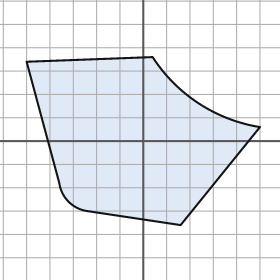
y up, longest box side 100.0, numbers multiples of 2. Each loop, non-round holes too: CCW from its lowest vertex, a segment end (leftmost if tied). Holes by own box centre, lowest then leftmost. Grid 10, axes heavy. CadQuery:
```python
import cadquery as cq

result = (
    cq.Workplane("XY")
    .moveTo(16.0, -36.0)
    .lineTo(50.0, 6.0)
    .threePointArc((24.0, 16.0), (4.0, 36.0))
    .lineTo(-50.0, 34.0)
    .lineTo(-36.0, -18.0)
    .threePointArc((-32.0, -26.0), (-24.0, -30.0))
    .close()
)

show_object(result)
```